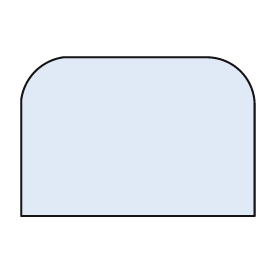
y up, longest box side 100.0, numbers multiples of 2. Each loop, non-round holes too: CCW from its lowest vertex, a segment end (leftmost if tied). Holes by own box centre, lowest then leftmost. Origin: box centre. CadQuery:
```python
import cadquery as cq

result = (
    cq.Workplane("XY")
    .moveTo(-50.0, -34.0)
    .lineTo(50.0, -34.0)
    .lineTo(50.0, 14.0)
    .threePointArc((44.0, 28.0), (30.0, 34.0))
    .lineTo(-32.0, 34.0)
    .threePointArc((-44.0, 28.0), (-50.0, 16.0))
    .close()
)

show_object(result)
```